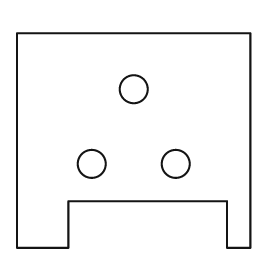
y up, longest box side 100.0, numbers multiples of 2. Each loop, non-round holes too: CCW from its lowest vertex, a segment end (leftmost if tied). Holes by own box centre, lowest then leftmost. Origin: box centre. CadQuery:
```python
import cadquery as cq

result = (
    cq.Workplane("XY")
    .moveTo(-50.0, -46.0)
    .lineTo(-28.0, -46.0)
    .lineTo(-28.0, -26.0)
    .lineTo(40.0, -26.0)
    .lineTo(40.0, -46.0)
    .lineTo(50.0, -46.0)
    .lineTo(50.0, 46.0)
    .lineTo(-50.0, 46.0)
    .close()
    .moveTo(-18.0, -10.0)
    .circle(6.0)
    .moveTo(18.0, -10.0)
    .circle(6.0)
    .moveTo(0.0, 22.0)
    .circle(6.0)
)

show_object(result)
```